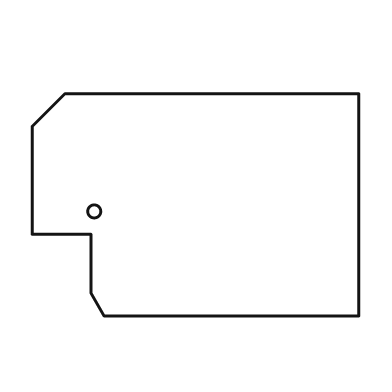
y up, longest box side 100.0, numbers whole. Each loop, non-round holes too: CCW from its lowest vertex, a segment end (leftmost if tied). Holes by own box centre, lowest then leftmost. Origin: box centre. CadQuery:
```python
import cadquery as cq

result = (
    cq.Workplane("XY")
    .moveTo(-28.0, -34.0)
    .lineTo(50.0, -34.0)
    .lineTo(50.0, 34.0)
    .lineTo(-40.0, 34.0)
    .lineTo(-50.0, 24.0)
    .lineTo(-50.0, -9.0)
    .lineTo(-32.0, -9.0)
    .lineTo(-32.0, -27.0)
    .close()
    .moveTo(-31.0, -2.0)
    .circle(2.0)
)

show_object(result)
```